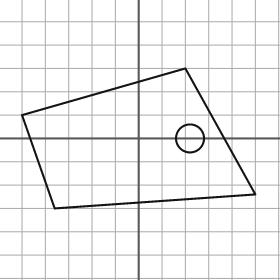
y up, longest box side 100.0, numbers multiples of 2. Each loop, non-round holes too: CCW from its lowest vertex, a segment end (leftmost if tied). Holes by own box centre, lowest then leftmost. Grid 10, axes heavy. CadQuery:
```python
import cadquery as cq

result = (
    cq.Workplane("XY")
    .moveTo(-36.0, -30.0)
    .lineTo(50.0, -24.0)
    .lineTo(20.0, 30.0)
    .lineTo(-50.0, 10.0)
    .close()
    .moveTo(22.0, 0.0)
    .circle(6.0)
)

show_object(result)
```